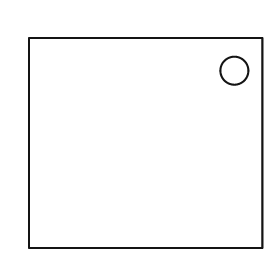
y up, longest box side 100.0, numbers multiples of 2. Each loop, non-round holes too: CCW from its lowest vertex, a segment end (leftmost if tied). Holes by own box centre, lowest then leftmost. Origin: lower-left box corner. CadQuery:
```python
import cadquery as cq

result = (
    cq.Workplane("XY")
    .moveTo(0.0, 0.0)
    .lineTo(100.0, 0.0)
    .lineTo(100.0, 90.0)
    .lineTo(0.0, 90.0)
    .close()
    .moveTo(88.0, 76.0)
    .circle(6.0)
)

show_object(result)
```